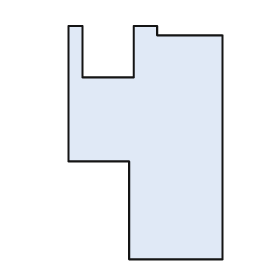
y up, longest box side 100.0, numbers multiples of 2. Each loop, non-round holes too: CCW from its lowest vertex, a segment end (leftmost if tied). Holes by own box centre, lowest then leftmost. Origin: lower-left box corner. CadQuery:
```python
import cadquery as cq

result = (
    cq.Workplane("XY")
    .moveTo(26.0, 0.0)
    .lineTo(66.0, 0.0)
    .lineTo(66.0, 96.0)
    .lineTo(38.0, 96.0)
    .lineTo(38.0, 100.0)
    .lineTo(28.0, 100.0)
    .lineTo(28.0, 78.0)
    .lineTo(6.0, 78.0)
    .lineTo(6.0, 100.0)
    .lineTo(0.0, 100.0)
    .lineTo(0.0, 42.0)
    .lineTo(26.0, 42.0)
    .close()
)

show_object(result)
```